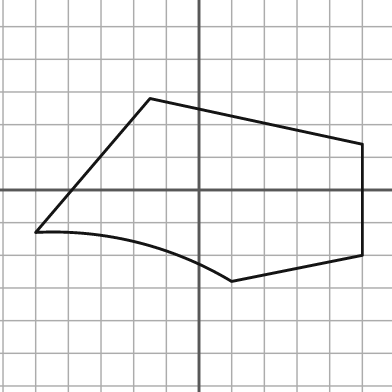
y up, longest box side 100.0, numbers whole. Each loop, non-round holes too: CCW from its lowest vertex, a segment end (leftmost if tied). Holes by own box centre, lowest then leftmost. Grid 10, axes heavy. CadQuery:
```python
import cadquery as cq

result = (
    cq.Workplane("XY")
    .moveTo(10.0, -28.0)
    .lineTo(50.0, -20.0)
    .lineTo(50.0, 14.0)
    .lineTo(-15.0, 28.0)
    .lineTo(-50.0, -13.0)
    .threePointArc((-19.0, -16.0), (10.0, -28.0))
    .close()
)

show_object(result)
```